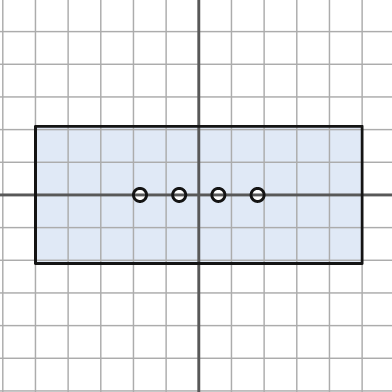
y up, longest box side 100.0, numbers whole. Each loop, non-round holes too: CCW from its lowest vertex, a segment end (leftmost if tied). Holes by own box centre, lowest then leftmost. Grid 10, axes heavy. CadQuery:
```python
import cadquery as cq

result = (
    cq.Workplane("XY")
    .moveTo(-50.0, -21.0)
    .lineTo(50.0, -21.0)
    .lineTo(50.0, 21.0)
    .lineTo(-50.0, 21.0)
    .close()
    .moveTo(-18.0, 0.0)
    .circle(2.0)
    .moveTo(-6.0, 0.0)
    .circle(2.0)
    .moveTo(6.0, 0.0)
    .circle(2.0)
    .moveTo(18.0, 0.0)
    .circle(2.0)
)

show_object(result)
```